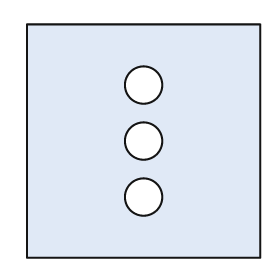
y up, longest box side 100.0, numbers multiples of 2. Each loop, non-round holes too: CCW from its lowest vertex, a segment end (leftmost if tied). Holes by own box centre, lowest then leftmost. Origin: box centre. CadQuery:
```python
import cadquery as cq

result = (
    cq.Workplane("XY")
    .moveTo(-50.0, -50.0)
    .lineTo(50.0, -50.0)
    .lineTo(50.0, 50.0)
    .lineTo(-50.0, 50.0)
    .close()
    .moveTo(0.0, -24.0)
    .circle(8.0)
    .moveTo(0.0, 0.0)
    .circle(8.0)
    .moveTo(0.0, 24.0)
    .circle(8.0)
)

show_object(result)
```